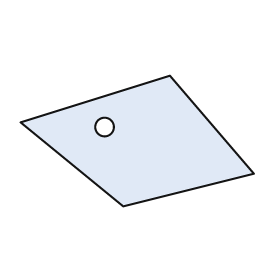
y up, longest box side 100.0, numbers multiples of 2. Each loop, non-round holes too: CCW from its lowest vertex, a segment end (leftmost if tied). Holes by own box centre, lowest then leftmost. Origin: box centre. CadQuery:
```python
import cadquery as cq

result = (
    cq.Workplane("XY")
    .moveTo(-6.0, -28.0)
    .lineTo(50.0, -14.0)
    .lineTo(14.0, 28.0)
    .lineTo(-50.0, 8.0)
    .close()
    .moveTo(-14.0, 6.0)
    .circle(4.0)
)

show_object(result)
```